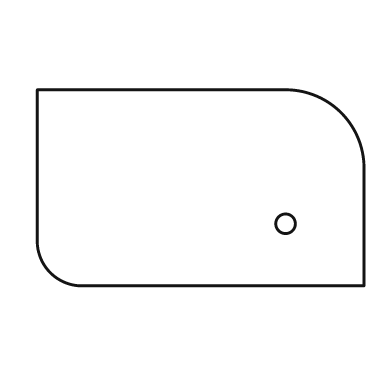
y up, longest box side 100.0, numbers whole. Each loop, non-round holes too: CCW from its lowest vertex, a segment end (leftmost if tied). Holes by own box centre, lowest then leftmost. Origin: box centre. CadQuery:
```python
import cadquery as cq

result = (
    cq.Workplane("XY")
    .moveTo(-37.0, -30.0)
    .lineTo(50.0, -30.0)
    .lineTo(50.0, 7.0)
    .threePointArc((43.0, 23.0), (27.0, 30.0))
    .lineTo(-50.0, 30.0)
    .lineTo(-50.0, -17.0)
    .threePointArc((-46.0, -26.0), (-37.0, -30.0))
    .close()
    .moveTo(26.0, -11.0)
    .circle(3.0)
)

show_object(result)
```